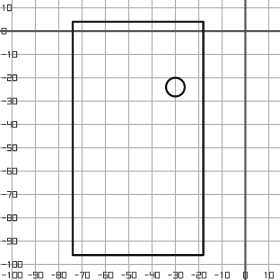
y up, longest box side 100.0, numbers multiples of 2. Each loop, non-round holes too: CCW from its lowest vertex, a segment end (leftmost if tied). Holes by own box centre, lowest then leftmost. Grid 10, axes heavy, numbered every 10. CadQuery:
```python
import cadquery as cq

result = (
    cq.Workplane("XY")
    .moveTo(-74.0, -96.0)
    .lineTo(-18.0, -96.0)
    .lineTo(-18.0, 4.0)
    .lineTo(-74.0, 4.0)
    .close()
    .moveTo(-30.0, -24.0)
    .circle(4.0)
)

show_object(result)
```